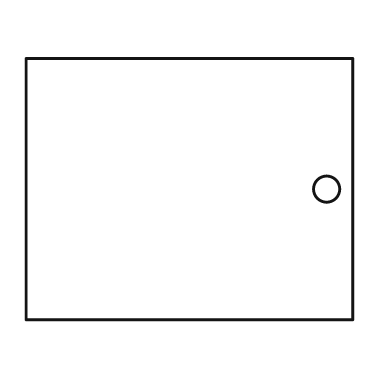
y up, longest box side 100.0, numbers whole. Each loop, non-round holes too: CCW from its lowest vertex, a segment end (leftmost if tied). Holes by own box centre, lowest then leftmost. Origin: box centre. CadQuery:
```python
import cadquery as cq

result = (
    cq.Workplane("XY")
    .moveTo(-50.0, -40.0)
    .lineTo(50.0, -40.0)
    .lineTo(50.0, 40.0)
    .lineTo(-50.0, 40.0)
    .close()
    .moveTo(42.0, 0.0)
    .circle(4.0)
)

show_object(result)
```